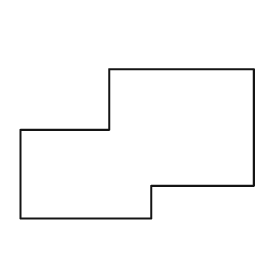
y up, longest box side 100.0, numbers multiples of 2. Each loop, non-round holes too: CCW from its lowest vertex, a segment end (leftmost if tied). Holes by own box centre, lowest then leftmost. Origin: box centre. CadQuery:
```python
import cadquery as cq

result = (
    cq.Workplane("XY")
    .moveTo(-50.0, -32.0)
    .lineTo(6.0, -32.0)
    .lineTo(6.0, -18.0)
    .lineTo(50.0, -18.0)
    .lineTo(50.0, 32.0)
    .lineTo(-12.0, 32.0)
    .lineTo(-12.0, 6.0)
    .lineTo(-50.0, 6.0)
    .close()
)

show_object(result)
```